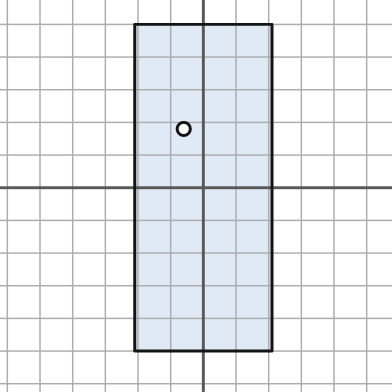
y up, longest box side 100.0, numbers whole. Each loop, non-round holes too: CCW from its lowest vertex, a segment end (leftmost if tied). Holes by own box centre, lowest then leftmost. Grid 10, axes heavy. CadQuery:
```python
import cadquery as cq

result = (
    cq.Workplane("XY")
    .moveTo(-21.0, -50.0)
    .lineTo(21.0, -50.0)
    .lineTo(21.0, 50.0)
    .lineTo(-21.0, 50.0)
    .close()
    .moveTo(-6.0, 18.0)
    .circle(2.0)
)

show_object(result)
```